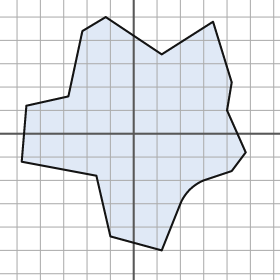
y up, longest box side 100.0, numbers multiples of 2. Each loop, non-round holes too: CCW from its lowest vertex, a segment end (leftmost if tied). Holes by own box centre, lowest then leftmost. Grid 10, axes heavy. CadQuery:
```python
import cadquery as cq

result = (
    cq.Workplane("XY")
    .moveTo(12.0, -50.0)
    .lineTo(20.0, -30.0)
    .threePointArc((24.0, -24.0), (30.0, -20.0))
    .lineTo(42.0, -16.0)
    .lineTo(48.0, -8.0)
    .lineTo(40.0, 10.0)
    .lineTo(42.0, 22.0)
    .lineTo(34.0, 48.0)
    .lineTo(12.0, 34.0)
    .lineTo(-12.0, 50.0)
    .lineTo(-22.0, 44.0)
    .lineTo(-28.0, 16.0)
    .lineTo(-46.0, 12.0)
    .lineTo(-48.0, -12.0)
    .lineTo(-16.0, -18.0)
    .lineTo(-10.0, -44.0)
    .close()
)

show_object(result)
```